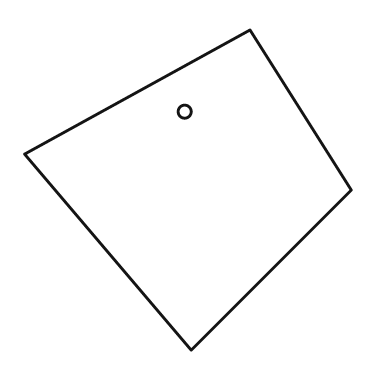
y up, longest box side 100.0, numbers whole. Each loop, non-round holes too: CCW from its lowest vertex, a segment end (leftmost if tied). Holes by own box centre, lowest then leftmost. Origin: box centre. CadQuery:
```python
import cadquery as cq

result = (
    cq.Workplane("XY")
    .moveTo(1.0, -49.0)
    .lineTo(50.0, 0.0)
    .lineTo(19.0, 49.0)
    .lineTo(-50.0, 11.0)
    .close()
    .moveTo(-1.0, 24.0)
    .circle(2.0)
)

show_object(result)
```